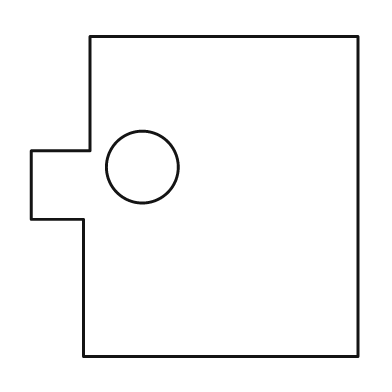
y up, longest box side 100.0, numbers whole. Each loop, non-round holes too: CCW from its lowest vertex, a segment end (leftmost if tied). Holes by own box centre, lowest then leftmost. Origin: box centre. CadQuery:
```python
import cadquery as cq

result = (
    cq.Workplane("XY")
    .moveTo(-34.0, -49.0)
    .lineTo(50.0, -49.0)
    .lineTo(50.0, 49.0)
    .lineTo(-32.0, 49.0)
    .lineTo(-32.0, 14.0)
    .lineTo(-50.0, 14.0)
    .lineTo(-50.0, -7.0)
    .lineTo(-34.0, -7.0)
    .close()
    .moveTo(-16.0, 9.0)
    .circle(11.0)
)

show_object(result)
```